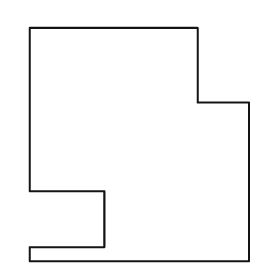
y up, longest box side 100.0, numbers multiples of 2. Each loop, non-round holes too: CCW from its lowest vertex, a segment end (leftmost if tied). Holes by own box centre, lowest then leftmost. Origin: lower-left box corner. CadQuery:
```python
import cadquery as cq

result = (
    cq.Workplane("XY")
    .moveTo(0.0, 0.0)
    .lineTo(94.0, 0.0)
    .lineTo(94.0, 68.0)
    .lineTo(72.0, 68.0)
    .lineTo(72.0, 100.0)
    .lineTo(0.0, 100.0)
    .lineTo(0.0, 30.0)
    .lineTo(32.0, 30.0)
    .lineTo(32.0, 6.0)
    .lineTo(0.0, 6.0)
    .close()
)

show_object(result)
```